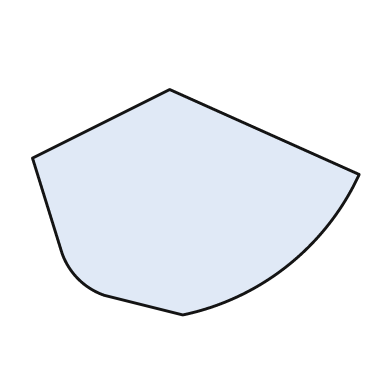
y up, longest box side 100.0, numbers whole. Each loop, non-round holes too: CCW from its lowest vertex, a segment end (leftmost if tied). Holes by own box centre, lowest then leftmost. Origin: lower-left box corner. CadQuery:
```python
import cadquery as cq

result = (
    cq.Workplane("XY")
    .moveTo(46.0, 0.0)
    .threePointArc((78.0, 15.0), (100.0, 43.0))
    .lineTo(42.0, 69.0)
    .lineTo(0.0, 48.0)
    .lineTo(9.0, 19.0)
    .threePointArc((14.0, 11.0), (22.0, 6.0))
    .close()
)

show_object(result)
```